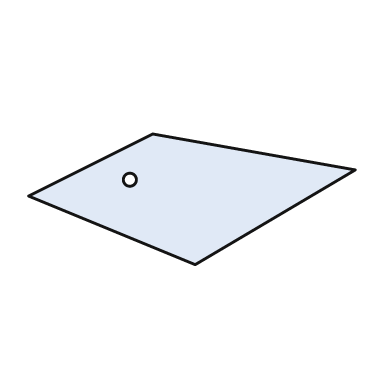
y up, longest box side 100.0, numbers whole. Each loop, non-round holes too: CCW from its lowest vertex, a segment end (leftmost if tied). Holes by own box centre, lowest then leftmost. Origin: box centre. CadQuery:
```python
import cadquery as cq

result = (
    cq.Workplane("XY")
    .moveTo(1.0, -20.0)
    .lineTo(50.0, 9.0)
    .lineTo(-12.0, 20.0)
    .lineTo(-50.0, 1.0)
    .close()
    .moveTo(-19.0, 6.0)
    .circle(2.0)
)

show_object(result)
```